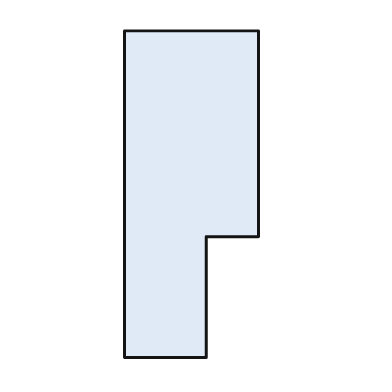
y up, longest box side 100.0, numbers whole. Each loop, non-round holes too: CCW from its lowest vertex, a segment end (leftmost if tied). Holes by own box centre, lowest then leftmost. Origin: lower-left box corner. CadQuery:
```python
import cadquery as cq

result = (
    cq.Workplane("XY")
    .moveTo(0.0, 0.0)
    .lineTo(25.0, 0.0)
    .lineTo(25.0, 37.0)
    .lineTo(41.0, 37.0)
    .lineTo(41.0, 100.0)
    .lineTo(0.0, 100.0)
    .close()
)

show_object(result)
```